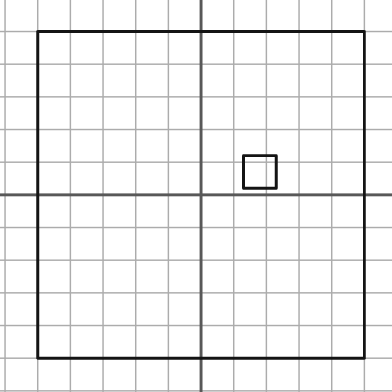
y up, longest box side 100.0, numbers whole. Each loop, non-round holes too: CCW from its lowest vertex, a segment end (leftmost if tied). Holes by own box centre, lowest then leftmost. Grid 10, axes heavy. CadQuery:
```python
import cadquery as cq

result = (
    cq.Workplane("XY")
    .moveTo(-50.0, -50.0)
    .lineTo(50.0, -50.0)
    .lineTo(50.0, 50.0)
    .lineTo(-50.0, 50.0)
    .close()
    .moveTo(13.0, 2.0)
    .lineTo(23.0, 2.0)
    .lineTo(23.0, 12.0)
    .lineTo(13.0, 12.0)
    .close()
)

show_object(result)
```